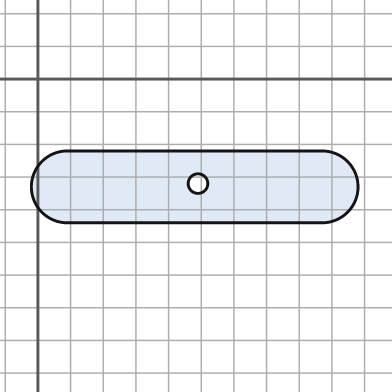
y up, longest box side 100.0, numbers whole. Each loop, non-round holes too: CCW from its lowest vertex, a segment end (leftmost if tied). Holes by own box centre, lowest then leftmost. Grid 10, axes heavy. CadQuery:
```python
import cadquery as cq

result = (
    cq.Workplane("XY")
    .moveTo(9.0, -44.0)
    .lineTo(87.0, -44.0)
    .threePointArc((98.0, -33.0), (87.0, -22.0))
    .lineTo(9.0, -22.0)
    .threePointArc((-2.0, -33.0), (9.0, -44.0))
    .close()
    .moveTo(49.0, -32.0)
    .circle(3.0)
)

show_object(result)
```